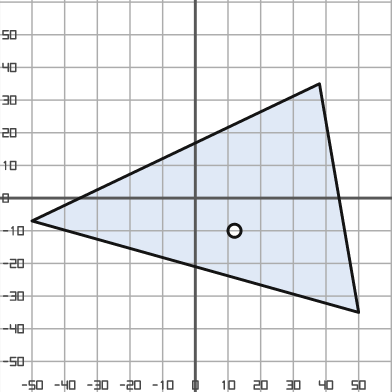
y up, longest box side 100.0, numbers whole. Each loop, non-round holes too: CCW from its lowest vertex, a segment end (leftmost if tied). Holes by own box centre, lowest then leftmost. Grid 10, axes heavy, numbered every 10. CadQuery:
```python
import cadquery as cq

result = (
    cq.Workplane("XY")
    .moveTo(50.0, -35.0)
    .lineTo(38.0, 35.0)
    .lineTo(-50.0, -7.0)
    .close()
    .moveTo(12.0, -10.0)
    .circle(2.0)
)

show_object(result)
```